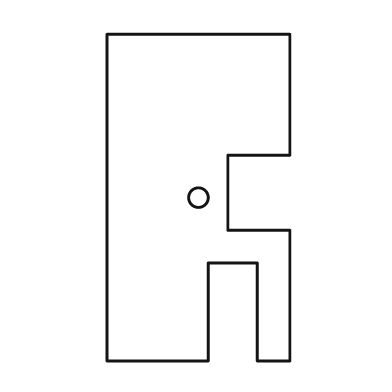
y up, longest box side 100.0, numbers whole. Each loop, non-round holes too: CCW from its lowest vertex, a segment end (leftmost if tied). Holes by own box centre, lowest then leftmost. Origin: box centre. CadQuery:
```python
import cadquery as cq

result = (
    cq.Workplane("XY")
    .moveTo(-28.0, -50.0)
    .lineTo(3.0, -50.0)
    .lineTo(3.0, -20.0)
    .lineTo(18.0, -20.0)
    .lineTo(18.0, -50.0)
    .lineTo(28.0, -50.0)
    .lineTo(28.0, -10.0)
    .lineTo(9.0, -10.0)
    .lineTo(9.0, 13.0)
    .lineTo(28.0, 13.0)
    .lineTo(28.0, 50.0)
    .lineTo(-28.0, 50.0)
    .close()
    .moveTo(0.0, 0.0)
    .circle(3.0)
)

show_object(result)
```